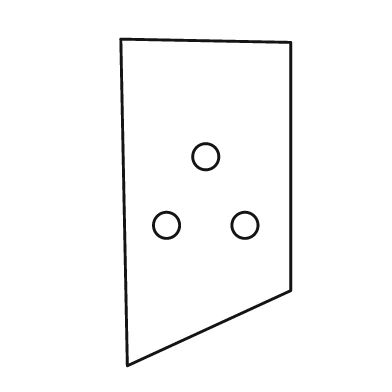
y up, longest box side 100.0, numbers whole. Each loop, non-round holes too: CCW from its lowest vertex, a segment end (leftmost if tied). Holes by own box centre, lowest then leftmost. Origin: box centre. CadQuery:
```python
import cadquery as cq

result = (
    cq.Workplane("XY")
    .moveTo(-24.0, -50.0)
    .lineTo(26.0, -27.0)
    .lineTo(26.0, 49.0)
    .lineTo(-26.0, 50.0)
    .close()
    .moveTo(-12.0, -7.0)
    .circle(4.0)
    .moveTo(12.0, -7.0)
    .circle(4.0)
    .moveTo(0.0, 14.0)
    .circle(4.0)
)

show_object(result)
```